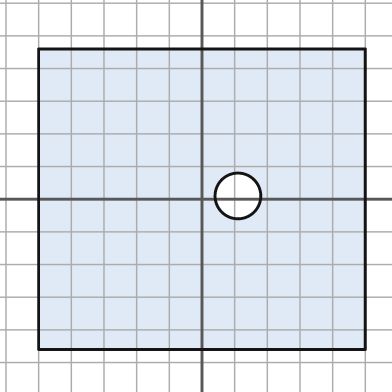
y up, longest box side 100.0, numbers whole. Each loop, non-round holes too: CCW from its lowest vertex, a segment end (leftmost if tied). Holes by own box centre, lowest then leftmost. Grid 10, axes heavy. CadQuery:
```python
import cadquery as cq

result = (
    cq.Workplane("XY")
    .moveTo(-50.0, -46.0)
    .lineTo(50.0, -46.0)
    .lineTo(50.0, 46.0)
    .lineTo(-50.0, 46.0)
    .close()
    .moveTo(11.0, 1.0)
    .circle(7.0)
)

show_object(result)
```